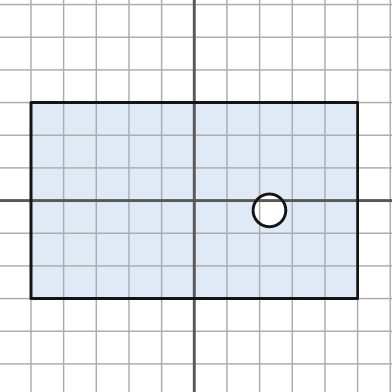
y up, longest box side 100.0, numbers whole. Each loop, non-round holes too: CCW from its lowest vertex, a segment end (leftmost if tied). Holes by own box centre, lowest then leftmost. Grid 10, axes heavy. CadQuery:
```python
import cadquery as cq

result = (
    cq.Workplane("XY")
    .moveTo(-50.0, -30.0)
    .lineTo(50.0, -30.0)
    .lineTo(50.0, 30.0)
    .lineTo(-50.0, 30.0)
    .close()
    .moveTo(23.0, -3.0)
    .circle(5.0)
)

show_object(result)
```